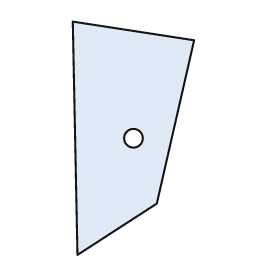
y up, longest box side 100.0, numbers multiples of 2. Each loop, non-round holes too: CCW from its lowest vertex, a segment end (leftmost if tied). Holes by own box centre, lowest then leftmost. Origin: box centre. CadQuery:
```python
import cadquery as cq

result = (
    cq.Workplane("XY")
    .moveTo(-24.0, -50.0)
    .lineTo(10.0, -28.0)
    .lineTo(26.0, 42.0)
    .lineTo(-26.0, 50.0)
    .close()
    .moveTo(0.0, 0.0)
    .circle(4.0)
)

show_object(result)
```